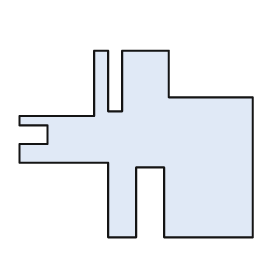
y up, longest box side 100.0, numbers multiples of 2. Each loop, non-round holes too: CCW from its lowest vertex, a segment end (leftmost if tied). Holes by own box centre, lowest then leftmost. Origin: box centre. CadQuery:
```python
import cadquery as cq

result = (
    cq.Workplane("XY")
    .moveTo(-12.0, -40.0)
    .lineTo(0.0, -40.0)
    .lineTo(0.0, -10.0)
    .lineTo(12.0, -10.0)
    .lineTo(12.0, -40.0)
    .lineTo(50.0, -40.0)
    .lineTo(50.0, 20.0)
    .lineTo(14.0, 20.0)
    .lineTo(14.0, 40.0)
    .lineTo(-6.0, 40.0)
    .lineTo(-6.0, 14.0)
    .lineTo(-12.0, 14.0)
    .lineTo(-12.0, 40.0)
    .lineTo(-18.0, 40.0)
    .lineTo(-18.0, 12.0)
    .lineTo(-50.0, 12.0)
    .lineTo(-50.0, 8.0)
    .lineTo(-38.0, 8.0)
    .lineTo(-38.0, 0.0)
    .lineTo(-50.0, 0.0)
    .lineTo(-50.0, -8.0)
    .lineTo(-12.0, -8.0)
    .close()
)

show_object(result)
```